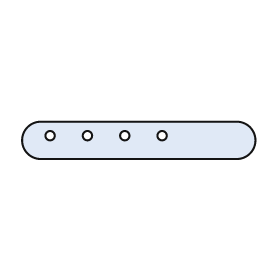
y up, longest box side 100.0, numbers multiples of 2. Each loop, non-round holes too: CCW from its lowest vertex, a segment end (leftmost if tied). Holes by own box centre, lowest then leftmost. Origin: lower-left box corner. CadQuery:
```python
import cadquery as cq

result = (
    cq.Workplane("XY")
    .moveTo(8.0, 0.0)
    .lineTo(92.0, 0.0)
    .threePointArc((100.0, 8.0), (92.0, 16.0))
    .lineTo(8.0, 16.0)
    .threePointArc((0.0, 8.0), (8.0, 0.0))
    .close()
    .moveTo(12.0, 10.0)
    .circle(2.0)
    .moveTo(28.0, 10.0)
    .circle(2.0)
    .moveTo(44.0, 10.0)
    .circle(2.0)
    .moveTo(60.0, 10.0)
    .circle(2.0)
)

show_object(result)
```